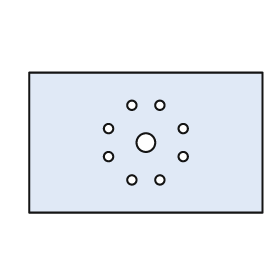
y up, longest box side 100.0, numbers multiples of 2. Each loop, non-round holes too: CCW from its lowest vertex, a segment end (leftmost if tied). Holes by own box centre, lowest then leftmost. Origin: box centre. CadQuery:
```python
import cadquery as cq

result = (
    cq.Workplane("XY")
    .moveTo(-50.0, -30.0)
    .lineTo(50.0, -30.0)
    .lineTo(50.0, 30.0)
    .lineTo(-50.0, 30.0)
    .close()
    .moveTo(-6.0, -16.0)
    .circle(2.0)
    .moveTo(6.0, -16.0)
    .circle(2.0)
    .moveTo(-16.0, -6.0)
    .circle(2.0)
    .moveTo(16.0, -6.0)
    .circle(2.0)
    .moveTo(0.0, 0.0)
    .circle(4.0)
    .moveTo(-16.0, 6.0)
    .circle(2.0)
    .moveTo(16.0, 6.0)
    .circle(2.0)
    .moveTo(-6.0, 16.0)
    .circle(2.0)
    .moveTo(6.0, 16.0)
    .circle(2.0)
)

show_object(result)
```